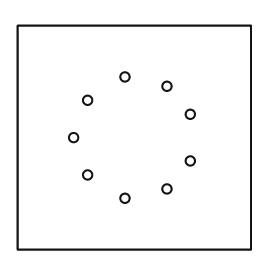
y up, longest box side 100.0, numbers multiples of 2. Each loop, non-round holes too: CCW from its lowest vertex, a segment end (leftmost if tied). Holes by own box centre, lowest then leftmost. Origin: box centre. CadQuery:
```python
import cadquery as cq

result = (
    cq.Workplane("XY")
    .moveTo(-50.0, -48.0)
    .lineTo(50.0, -48.0)
    .lineTo(50.0, 48.0)
    .lineTo(-50.0, 48.0)
    .close()
    .moveTo(-4.0, -26.0)
    .circle(2.0)
    .moveTo(14.0, -22.0)
    .circle(2.0)
    .moveTo(-20.0, -16.0)
    .circle(2.0)
    .moveTo(24.0, -10.0)
    .circle(2.0)
    .moveTo(-26.0, 0.0)
    .circle(2.0)
    .moveTo(24.0, 10.0)
    .circle(2.0)
    .moveTo(-20.0, 16.0)
    .circle(2.0)
    .moveTo(14.0, 22.0)
    .circle(2.0)
    .moveTo(-4.0, 26.0)
    .circle(2.0)
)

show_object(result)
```